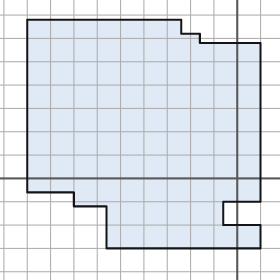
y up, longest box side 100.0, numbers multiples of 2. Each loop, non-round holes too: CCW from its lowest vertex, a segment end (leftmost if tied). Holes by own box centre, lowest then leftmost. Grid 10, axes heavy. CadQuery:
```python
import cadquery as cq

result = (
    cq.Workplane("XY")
    .moveTo(-56.0, -30.0)
    .lineTo(10.0, -30.0)
    .lineTo(10.0, -20.0)
    .lineTo(-6.0, -20.0)
    .lineTo(-6.0, -10.0)
    .lineTo(10.0, -10.0)
    .lineTo(10.0, 58.0)
    .lineTo(-16.0, 58.0)
    .lineTo(-16.0, 62.0)
    .lineTo(-24.0, 62.0)
    .lineTo(-24.0, 68.0)
    .lineTo(-90.0, 68.0)
    .lineTo(-90.0, -6.0)
    .lineTo(-70.0, -6.0)
    .lineTo(-70.0, -12.0)
    .lineTo(-56.0, -12.0)
    .close()
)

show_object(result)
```